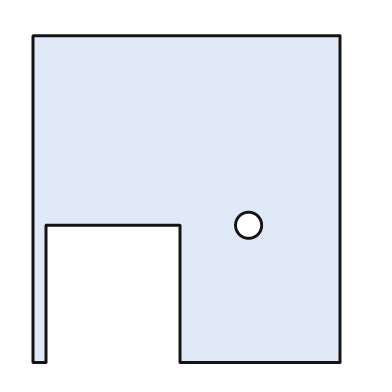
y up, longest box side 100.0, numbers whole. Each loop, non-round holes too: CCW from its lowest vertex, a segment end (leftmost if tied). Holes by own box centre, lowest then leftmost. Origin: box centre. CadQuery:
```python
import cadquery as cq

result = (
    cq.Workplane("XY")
    .moveTo(-47.0, -50.0)
    .lineTo(-43.0, -50.0)
    .lineTo(-43.0, -8.0)
    .lineTo(-2.0, -8.0)
    .lineTo(-2.0, -50.0)
    .lineTo(47.0, -50.0)
    .lineTo(47.0, 50.0)
    .lineTo(-47.0, 50.0)
    .close()
    .moveTo(19.0, -8.0)
    .circle(4.0)
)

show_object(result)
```